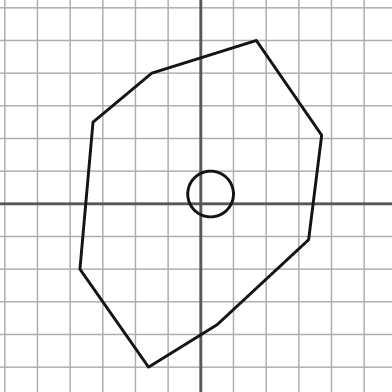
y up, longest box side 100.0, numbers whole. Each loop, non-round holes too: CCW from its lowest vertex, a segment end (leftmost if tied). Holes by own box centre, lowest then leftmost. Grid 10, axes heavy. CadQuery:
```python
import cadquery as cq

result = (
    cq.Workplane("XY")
    .moveTo(-16.0, -50.0)
    .lineTo(5.0, -37.0)
    .lineTo(33.0, -11.0)
    .lineTo(37.0, 21.0)
    .lineTo(17.0, 50.0)
    .lineTo(-15.0, 40.0)
    .lineTo(-33.0, 25.0)
    .lineTo(-37.0, -20.0)
    .close()
    .moveTo(3.0, 3.0)
    .circle(7.0)
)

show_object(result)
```